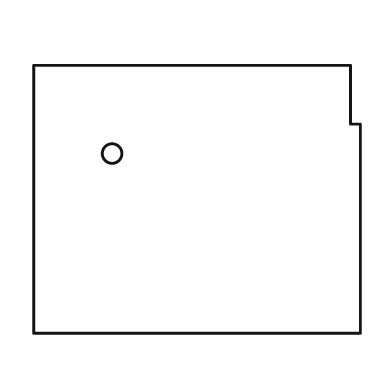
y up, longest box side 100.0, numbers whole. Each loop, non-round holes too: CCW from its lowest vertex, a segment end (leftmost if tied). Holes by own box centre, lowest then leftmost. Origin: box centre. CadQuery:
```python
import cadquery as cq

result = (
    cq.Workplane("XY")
    .moveTo(-50.0, -41.0)
    .lineTo(50.0, -41.0)
    .lineTo(50.0, 23.0)
    .lineTo(47.0, 23.0)
    .lineTo(47.0, 41.0)
    .lineTo(-50.0, 41.0)
    .close()
    .moveTo(-26.0, 14.0)
    .circle(3.0)
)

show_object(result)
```